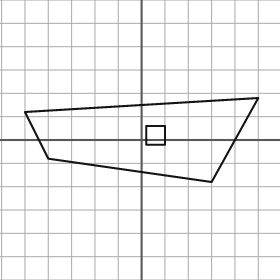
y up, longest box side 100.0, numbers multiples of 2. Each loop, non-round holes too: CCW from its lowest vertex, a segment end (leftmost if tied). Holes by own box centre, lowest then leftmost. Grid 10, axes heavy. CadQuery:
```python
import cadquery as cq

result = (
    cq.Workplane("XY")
    .moveTo(30.0, -18.0)
    .lineTo(50.0, 18.0)
    .lineTo(-50.0, 12.0)
    .lineTo(-40.0, -8.0)
    .close()
    .moveTo(2.0, -2.0)
    .lineTo(10.0, -2.0)
    .lineTo(10.0, 6.0)
    .lineTo(2.0, 6.0)
    .close()
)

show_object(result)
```